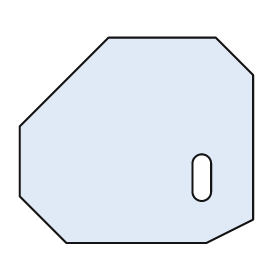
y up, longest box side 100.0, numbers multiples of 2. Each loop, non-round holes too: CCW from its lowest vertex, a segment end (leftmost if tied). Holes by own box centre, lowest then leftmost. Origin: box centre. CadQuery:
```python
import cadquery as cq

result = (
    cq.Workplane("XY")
    .moveTo(-30.0, -44.0)
    .lineTo(30.0, -44.0)
    .lineTo(50.0, -34.0)
    .lineTo(50.0, 28.0)
    .lineTo(34.0, 44.0)
    .lineTo(-12.0, 44.0)
    .lineTo(-50.0, 6.0)
    .lineTo(-50.0, -24.0)
    .close()
    .moveTo(24.0, -22.0)
    .threePointArc((28.0, -26.0), (32.0, -22.0))
    .lineTo(32.0, -10.0)
    .threePointArc((28.0, -6.0), (24.0, -10.0))
    .close()
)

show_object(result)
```